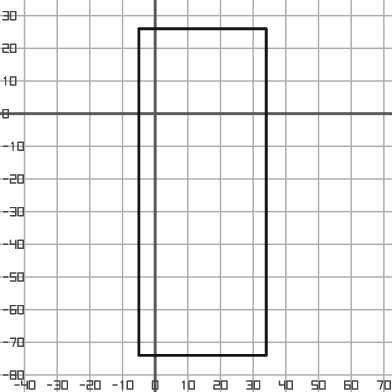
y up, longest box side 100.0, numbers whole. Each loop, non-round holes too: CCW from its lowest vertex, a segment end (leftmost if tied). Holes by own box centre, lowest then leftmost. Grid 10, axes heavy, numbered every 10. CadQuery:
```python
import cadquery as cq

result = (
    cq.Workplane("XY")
    .moveTo(-5.0, -74.0)
    .lineTo(34.0, -74.0)
    .lineTo(34.0, 26.0)
    .lineTo(-5.0, 26.0)
    .close()
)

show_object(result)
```